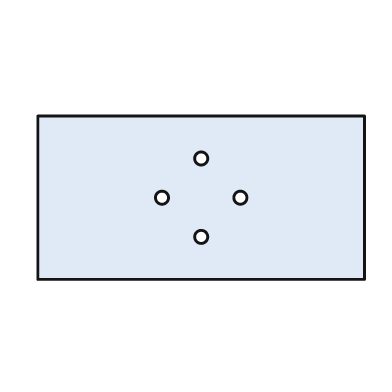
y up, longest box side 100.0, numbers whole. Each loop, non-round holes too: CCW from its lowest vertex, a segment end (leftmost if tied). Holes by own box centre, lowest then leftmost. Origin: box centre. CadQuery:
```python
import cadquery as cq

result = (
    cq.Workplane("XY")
    .moveTo(-50.0, -25.0)
    .lineTo(50.0, -25.0)
    .lineTo(50.0, 25.0)
    .lineTo(-50.0, 25.0)
    .close()
    .moveTo(0.0, -12.0)
    .circle(2.0)
    .moveTo(-12.0, 0.0)
    .circle(2.0)
    .moveTo(12.0, 0.0)
    .circle(2.0)
    .moveTo(0.0, 12.0)
    .circle(2.0)
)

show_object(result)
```